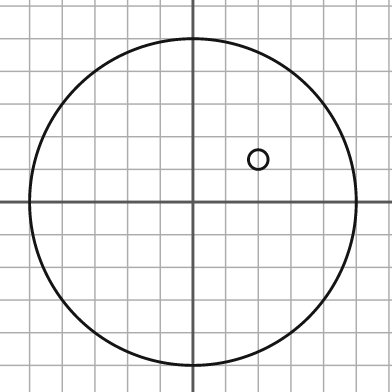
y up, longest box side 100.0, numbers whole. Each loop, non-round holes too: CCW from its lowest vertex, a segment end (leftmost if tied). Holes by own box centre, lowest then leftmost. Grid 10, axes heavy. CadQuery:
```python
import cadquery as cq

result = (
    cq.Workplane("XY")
    .moveTo(0.0, 0.0)
    .circle(50.0)
    .moveTo(20.0, 13.0)
    .circle(3.0)
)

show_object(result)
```